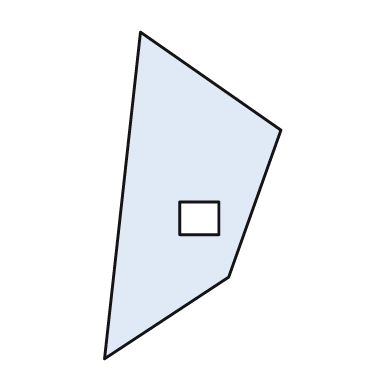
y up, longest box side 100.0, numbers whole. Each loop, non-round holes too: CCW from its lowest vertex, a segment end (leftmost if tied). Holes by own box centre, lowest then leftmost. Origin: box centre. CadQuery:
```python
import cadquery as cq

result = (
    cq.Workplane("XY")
    .moveTo(-27.0, -50.0)
    .lineTo(11.0, -25.0)
    .lineTo(27.0, 20.0)
    .lineTo(-16.0, 50.0)
    .close()
    .moveTo(-4.0, -12.0)
    .lineTo(8.0, -12.0)
    .lineTo(8.0, -2.0)
    .lineTo(-4.0, -2.0)
    .close()
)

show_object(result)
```